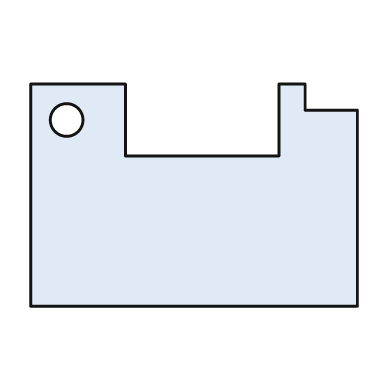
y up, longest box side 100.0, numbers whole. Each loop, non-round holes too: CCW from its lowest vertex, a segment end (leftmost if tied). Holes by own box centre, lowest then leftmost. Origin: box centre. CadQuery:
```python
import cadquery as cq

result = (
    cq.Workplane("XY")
    .moveTo(-50.0, -34.0)
    .lineTo(50.0, -34.0)
    .lineTo(50.0, 26.0)
    .lineTo(34.0, 26.0)
    .lineTo(34.0, 34.0)
    .lineTo(26.0, 34.0)
    .lineTo(26.0, 12.0)
    .lineTo(-21.0, 12.0)
    .lineTo(-21.0, 34.0)
    .lineTo(-50.0, 34.0)
    .close()
    .moveTo(-39.0, 23.0)
    .circle(5.0)
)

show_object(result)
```